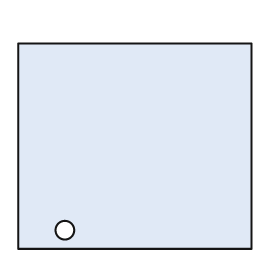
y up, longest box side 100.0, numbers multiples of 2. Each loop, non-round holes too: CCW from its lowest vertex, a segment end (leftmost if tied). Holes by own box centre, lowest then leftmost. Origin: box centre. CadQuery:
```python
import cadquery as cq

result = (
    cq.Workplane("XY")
    .moveTo(-50.0, -44.0)
    .lineTo(50.0, -44.0)
    .lineTo(50.0, 44.0)
    .lineTo(-50.0, 44.0)
    .close()
    .moveTo(-30.0, -36.0)
    .circle(4.0)
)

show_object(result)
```